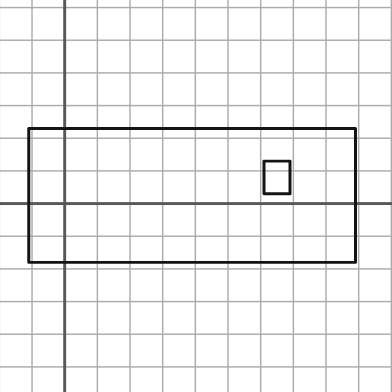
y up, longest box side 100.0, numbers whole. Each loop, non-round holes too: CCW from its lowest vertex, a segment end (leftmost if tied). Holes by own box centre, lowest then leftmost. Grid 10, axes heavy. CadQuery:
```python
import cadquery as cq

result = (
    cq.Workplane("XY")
    .moveTo(-11.0, -18.0)
    .lineTo(89.0, -18.0)
    .lineTo(89.0, 23.0)
    .lineTo(-11.0, 23.0)
    .close()
    .moveTo(61.0, 3.0)
    .lineTo(69.0, 3.0)
    .lineTo(69.0, 13.0)
    .lineTo(61.0, 13.0)
    .close()
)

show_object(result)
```